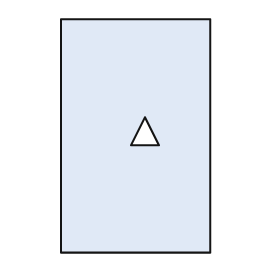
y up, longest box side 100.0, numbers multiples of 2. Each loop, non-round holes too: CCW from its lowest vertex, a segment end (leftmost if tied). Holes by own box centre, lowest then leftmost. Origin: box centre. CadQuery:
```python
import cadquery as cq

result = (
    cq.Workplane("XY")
    .moveTo(-32.0, -50.0)
    .lineTo(32.0, -50.0)
    .lineTo(32.0, 50.0)
    .lineTo(-32.0, 50.0)
    .close()
    .moveTo(-2.0, -4.0)
    .lineTo(10.0, -4.0)
    .lineTo(4.0, 8.0)
    .close()
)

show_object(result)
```